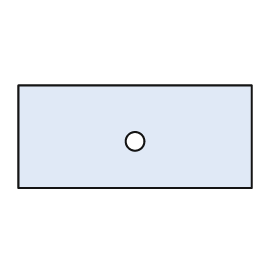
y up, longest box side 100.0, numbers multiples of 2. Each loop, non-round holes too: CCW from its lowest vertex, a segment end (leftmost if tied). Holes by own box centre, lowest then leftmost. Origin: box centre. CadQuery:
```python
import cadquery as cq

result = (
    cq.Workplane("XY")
    .moveTo(-50.0, -22.0)
    .lineTo(50.0, -22.0)
    .lineTo(50.0, 22.0)
    .lineTo(-50.0, 22.0)
    .close()
    .moveTo(0.0, -2.0)
    .circle(4.0)
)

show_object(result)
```